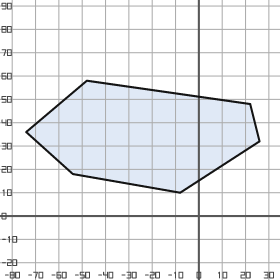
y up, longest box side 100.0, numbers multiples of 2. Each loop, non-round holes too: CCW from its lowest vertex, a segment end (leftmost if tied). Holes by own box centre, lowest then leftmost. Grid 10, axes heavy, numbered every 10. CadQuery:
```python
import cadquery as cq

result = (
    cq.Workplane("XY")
    .moveTo(-8.0, 10.0)
    .lineTo(26.0, 32.0)
    .lineTo(22.0, 48.0)
    .lineTo(-48.0, 58.0)
    .lineTo(-74.0, 36.0)
    .lineTo(-54.0, 18.0)
    .close()
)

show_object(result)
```